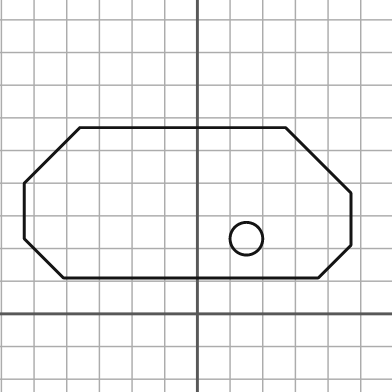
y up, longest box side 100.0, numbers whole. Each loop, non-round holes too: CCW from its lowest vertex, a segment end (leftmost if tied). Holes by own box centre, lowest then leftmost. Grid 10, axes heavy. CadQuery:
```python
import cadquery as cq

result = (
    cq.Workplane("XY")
    .moveTo(-41.0, 11.0)
    .lineTo(37.0, 11.0)
    .lineTo(47.0, 21.0)
    .lineTo(47.0, 37.0)
    .lineTo(27.0, 57.0)
    .lineTo(-36.0, 57.0)
    .lineTo(-53.0, 40.0)
    .lineTo(-53.0, 23.0)
    .close()
    .moveTo(15.0, 23.0)
    .circle(5.0)
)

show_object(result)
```